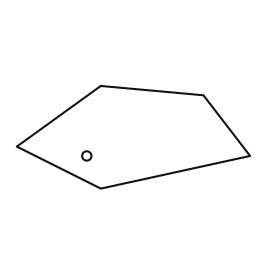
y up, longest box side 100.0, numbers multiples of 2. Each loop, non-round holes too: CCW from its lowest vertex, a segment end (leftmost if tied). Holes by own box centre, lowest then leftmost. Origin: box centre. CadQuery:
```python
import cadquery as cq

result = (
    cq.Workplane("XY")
    .moveTo(-14.0, -22.0)
    .lineTo(50.0, -8.0)
    .lineTo(30.0, 18.0)
    .lineTo(-14.0, 22.0)
    .lineTo(-50.0, -4.0)
    .close()
    .moveTo(-20.0, -8.0)
    .circle(2.0)
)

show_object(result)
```